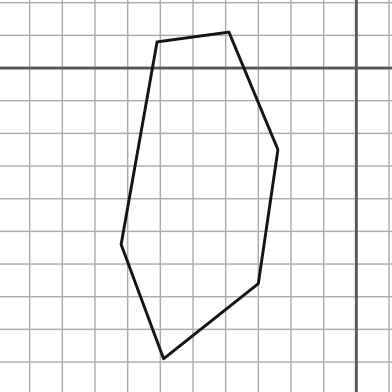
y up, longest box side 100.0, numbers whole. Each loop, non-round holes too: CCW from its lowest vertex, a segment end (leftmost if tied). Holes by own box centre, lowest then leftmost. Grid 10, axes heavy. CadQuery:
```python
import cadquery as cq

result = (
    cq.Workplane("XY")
    .moveTo(-59.0, -89.0)
    .lineTo(-30.0, -66.0)
    .lineTo(-24.0, -25.0)
    .lineTo(-39.0, 11.0)
    .lineTo(-61.0, 8.0)
    .lineTo(-72.0, -54.0)
    .close()
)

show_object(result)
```